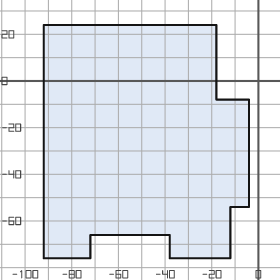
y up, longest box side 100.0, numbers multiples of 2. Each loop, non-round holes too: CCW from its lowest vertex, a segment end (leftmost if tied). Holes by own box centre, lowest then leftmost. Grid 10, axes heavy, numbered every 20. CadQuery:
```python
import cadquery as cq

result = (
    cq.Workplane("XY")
    .moveTo(-92.0, -76.0)
    .lineTo(-72.0, -76.0)
    .lineTo(-72.0, -66.0)
    .lineTo(-38.0, -66.0)
    .lineTo(-38.0, -76.0)
    .lineTo(-12.0, -76.0)
    .lineTo(-12.0, -54.0)
    .lineTo(-4.0, -54.0)
    .lineTo(-4.0, -8.0)
    .lineTo(-18.0, -8.0)
    .lineTo(-18.0, 24.0)
    .lineTo(-92.0, 24.0)
    .close()
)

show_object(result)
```